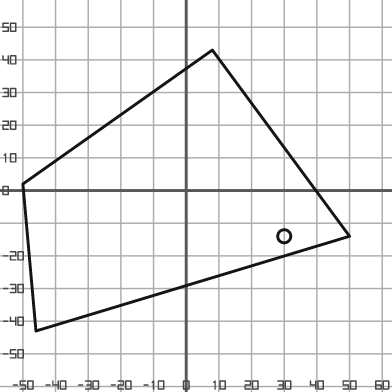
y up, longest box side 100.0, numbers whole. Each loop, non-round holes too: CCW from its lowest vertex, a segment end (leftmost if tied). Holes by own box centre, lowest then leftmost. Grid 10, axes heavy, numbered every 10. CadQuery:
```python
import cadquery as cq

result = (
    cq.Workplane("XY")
    .moveTo(-46.0, -43.0)
    .lineTo(50.0, -14.0)
    .lineTo(8.0, 43.0)
    .lineTo(-50.0, 2.0)
    .close()
    .moveTo(30.0, -14.0)
    .circle(2.0)
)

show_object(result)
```